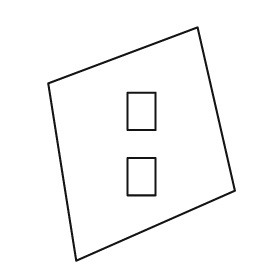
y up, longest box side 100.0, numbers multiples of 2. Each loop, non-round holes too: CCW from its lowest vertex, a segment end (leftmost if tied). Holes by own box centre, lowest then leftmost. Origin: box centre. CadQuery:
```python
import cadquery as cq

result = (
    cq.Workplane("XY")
    .moveTo(-28.0, -50.0)
    .lineTo(40.0, -20.0)
    .lineTo(24.0, 50.0)
    .lineTo(-40.0, 26.0)
    .close()
    .moveTo(-6.0, -22.0)
    .lineTo(6.0, -22.0)
    .lineTo(6.0, -6.0)
    .lineTo(-6.0, -6.0)
    .close()
    .moveTo(-6.0, 6.0)
    .lineTo(6.0, 6.0)
    .lineTo(6.0, 22.0)
    .lineTo(-6.0, 22.0)
    .close()
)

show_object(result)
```